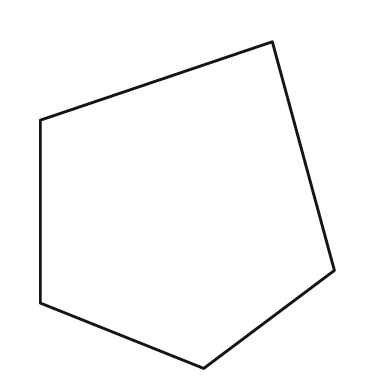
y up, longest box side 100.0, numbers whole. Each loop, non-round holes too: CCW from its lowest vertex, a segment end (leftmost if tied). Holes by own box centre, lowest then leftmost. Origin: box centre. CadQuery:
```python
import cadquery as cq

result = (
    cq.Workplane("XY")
    .moveTo(5.0, -50.0)
    .lineTo(45.0, -20.0)
    .lineTo(26.0, 50.0)
    .lineTo(-45.0, 26.0)
    .lineTo(-45.0, -30.0)
    .close()
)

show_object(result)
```